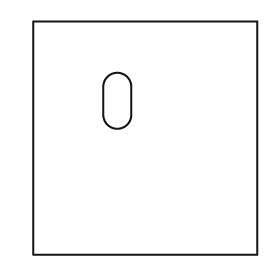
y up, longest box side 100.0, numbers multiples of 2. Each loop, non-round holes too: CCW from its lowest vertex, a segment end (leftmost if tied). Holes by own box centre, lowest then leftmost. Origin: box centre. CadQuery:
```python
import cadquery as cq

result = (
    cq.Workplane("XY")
    .moveTo(-48.0, -50.0)
    .lineTo(48.0, -50.0)
    .lineTo(48.0, 50.0)
    .lineTo(-48.0, 50.0)
    .close()
    .moveTo(-18.0, 10.0)
    .threePointArc((-12.0, 4.0), (-6.0, 10.0))
    .lineTo(-6.0, 22.0)
    .threePointArc((-12.0, 28.0), (-18.0, 22.0))
    .close()
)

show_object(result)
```